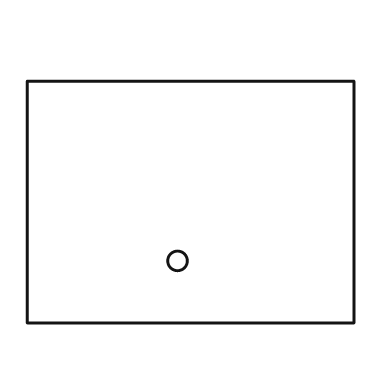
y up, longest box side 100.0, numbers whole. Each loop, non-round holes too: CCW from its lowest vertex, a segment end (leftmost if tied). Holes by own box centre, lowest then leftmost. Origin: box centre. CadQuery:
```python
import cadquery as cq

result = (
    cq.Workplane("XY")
    .moveTo(-50.0, -37.0)
    .lineTo(50.0, -37.0)
    .lineTo(50.0, 37.0)
    .lineTo(-50.0, 37.0)
    .close()
    .moveTo(-4.0, -18.0)
    .circle(3.0)
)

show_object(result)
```